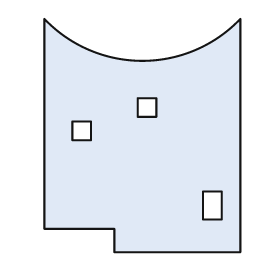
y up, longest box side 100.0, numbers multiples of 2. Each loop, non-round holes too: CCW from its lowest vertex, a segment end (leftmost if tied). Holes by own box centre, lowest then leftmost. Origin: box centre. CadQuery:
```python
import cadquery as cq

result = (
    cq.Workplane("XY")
    .moveTo(-12.0, -50.0)
    .lineTo(42.0, -50.0)
    .lineTo(42.0, 50.0)
    .threePointArc((0.0, 32.0), (-42.0, 50.0))
    .lineTo(-42.0, -40.0)
    .lineTo(-12.0, -40.0)
    .close()
    .moveTo(26.0, -36.0)
    .lineTo(34.0, -36.0)
    .lineTo(34.0, -24.0)
    .lineTo(26.0, -24.0)
    .close()
    .moveTo(-30.0, -2.0)
    .lineTo(-22.0, -2.0)
    .lineTo(-22.0, 6.0)
    .lineTo(-30.0, 6.0)
    .close()
    .moveTo(-2.0, 8.0)
    .lineTo(6.0, 8.0)
    .lineTo(6.0, 16.0)
    .lineTo(-2.0, 16.0)
    .close()
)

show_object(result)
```